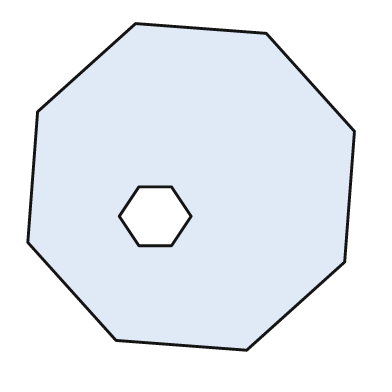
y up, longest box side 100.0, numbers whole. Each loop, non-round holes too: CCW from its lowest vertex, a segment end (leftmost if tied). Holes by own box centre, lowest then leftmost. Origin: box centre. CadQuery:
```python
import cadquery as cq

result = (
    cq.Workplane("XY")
    .moveTo(17.0, -50.0)
    .lineTo(47.0, -23.0)
    .lineTo(50.0, 17.0)
    .lineTo(23.0, 47.0)
    .lineTo(-17.0, 50.0)
    .lineTo(-47.0, 23.0)
    .lineTo(-50.0, -17.0)
    .lineTo(-23.0, -47.0)
    .close()
    .moveTo(-16.0, -18.0)
    .lineTo(-6.0, -18.0)
    .lineTo(0.0, -9.0)
    .lineTo(-6.0, 0.0)
    .lineTo(-16.0, 0.0)
    .lineTo(-22.0, -9.0)
    .close()
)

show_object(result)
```